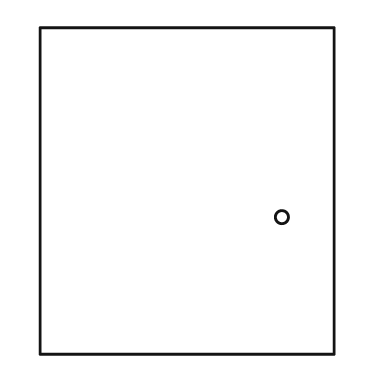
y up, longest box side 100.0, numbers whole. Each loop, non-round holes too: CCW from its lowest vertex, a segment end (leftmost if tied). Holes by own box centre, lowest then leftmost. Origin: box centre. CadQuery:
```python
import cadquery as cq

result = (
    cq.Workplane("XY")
    .moveTo(-45.0, -50.0)
    .lineTo(45.0, -50.0)
    .lineTo(45.0, 50.0)
    .lineTo(-45.0, 50.0)
    .close()
    .moveTo(29.0, -8.0)
    .circle(2.0)
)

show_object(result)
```